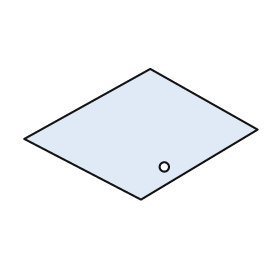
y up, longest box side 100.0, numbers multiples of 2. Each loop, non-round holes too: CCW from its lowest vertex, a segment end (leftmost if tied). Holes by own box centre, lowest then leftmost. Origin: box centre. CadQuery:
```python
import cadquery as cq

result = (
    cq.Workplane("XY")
    .moveTo(0.0, -28.0)
    .lineTo(50.0, 2.0)
    .lineTo(4.0, 28.0)
    .lineTo(-50.0, -2.0)
    .close()
    .moveTo(10.0, -14.0)
    .circle(2.0)
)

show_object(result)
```